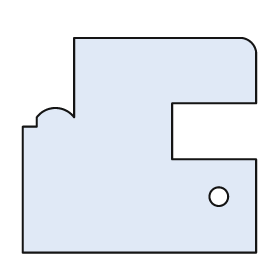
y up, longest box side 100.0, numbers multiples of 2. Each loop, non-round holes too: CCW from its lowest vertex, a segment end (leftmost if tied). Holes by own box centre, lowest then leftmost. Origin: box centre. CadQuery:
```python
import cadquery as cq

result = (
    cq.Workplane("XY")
    .moveTo(-50.0, -46.0)
    .lineTo(50.0, -46.0)
    .lineTo(50.0, -6.0)
    .lineTo(14.0, -6.0)
    .lineTo(14.0, 18.0)
    .lineTo(50.0, 18.0)
    .lineTo(50.0, 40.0)
    .threePointArc((48.0, 44.0), (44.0, 46.0))
    .lineTo(-28.0, 46.0)
    .lineTo(-28.0, 12.0)
    .threePointArc((-36.0, 16.0), (-44.0, 12.0))
    .lineTo(-44.0, 8.0)
    .lineTo(-50.0, 8.0)
    .close()
    .moveTo(34.0, -22.0)
    .circle(4.0)
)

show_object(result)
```